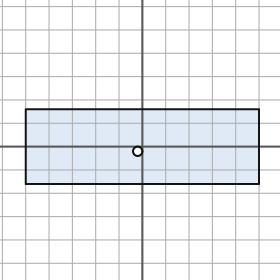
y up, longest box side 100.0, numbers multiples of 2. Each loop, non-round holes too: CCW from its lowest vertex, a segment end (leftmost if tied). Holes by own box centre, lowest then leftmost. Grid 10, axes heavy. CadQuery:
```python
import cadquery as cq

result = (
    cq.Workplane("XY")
    .moveTo(-50.0, -16.0)
    .lineTo(50.0, -16.0)
    .lineTo(50.0, 16.0)
    .lineTo(-50.0, 16.0)
    .close()
    .moveTo(-2.0, -2.0)
    .circle(2.0)
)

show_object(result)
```